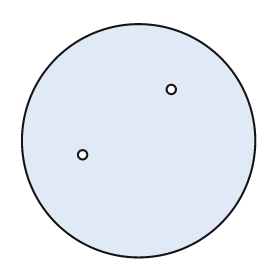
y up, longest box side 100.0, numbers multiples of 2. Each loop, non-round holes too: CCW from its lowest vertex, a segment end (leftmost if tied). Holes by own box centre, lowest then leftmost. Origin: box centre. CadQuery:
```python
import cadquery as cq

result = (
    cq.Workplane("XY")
    .moveTo(0.0, 0.0)
    .circle(50.0)
    .moveTo(-24.0, -6.0)
    .circle(2.0)
    .moveTo(14.0, 22.0)
    .circle(2.0)
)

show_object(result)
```